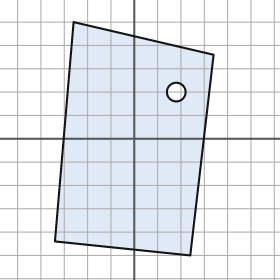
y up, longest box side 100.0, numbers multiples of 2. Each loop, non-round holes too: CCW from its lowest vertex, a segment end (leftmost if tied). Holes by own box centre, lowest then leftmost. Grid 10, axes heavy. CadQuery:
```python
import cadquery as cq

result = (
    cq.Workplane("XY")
    .moveTo(24.0, -50.0)
    .lineTo(34.0, 36.0)
    .lineTo(-26.0, 50.0)
    .lineTo(-34.0, -44.0)
    .close()
    .moveTo(18.0, 20.0)
    .circle(4.0)
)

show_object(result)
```